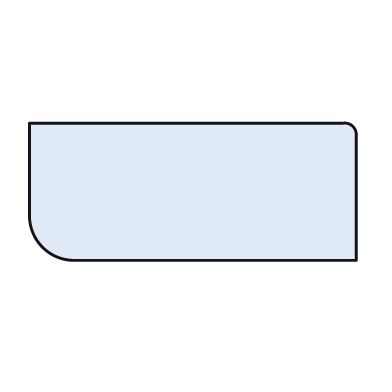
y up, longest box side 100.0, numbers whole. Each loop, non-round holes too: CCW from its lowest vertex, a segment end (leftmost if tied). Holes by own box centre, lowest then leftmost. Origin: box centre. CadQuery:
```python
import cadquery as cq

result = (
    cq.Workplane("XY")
    .moveTo(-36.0, -21.0)
    .lineTo(50.0, -21.0)
    .lineTo(50.0, 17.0)
    .threePointArc((49.0, 20.0), (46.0, 21.0))
    .lineTo(-50.0, 21.0)
    .lineTo(-50.0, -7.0)
    .threePointArc((-46.0, -17.0), (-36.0, -21.0))
    .close()
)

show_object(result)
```